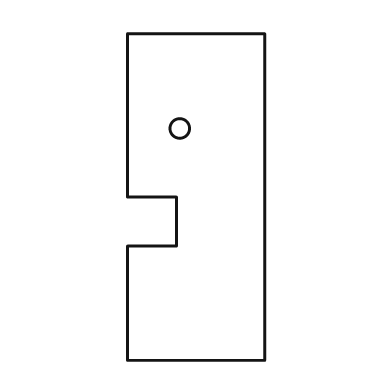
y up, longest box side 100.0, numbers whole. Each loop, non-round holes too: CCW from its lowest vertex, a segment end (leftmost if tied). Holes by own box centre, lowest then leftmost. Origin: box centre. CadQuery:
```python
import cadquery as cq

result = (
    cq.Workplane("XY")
    .moveTo(-21.0, -50.0)
    .lineTo(21.0, -50.0)
    .lineTo(21.0, 50.0)
    .lineTo(-21.0, 50.0)
    .lineTo(-21.0, 0.0)
    .lineTo(-6.0, 0.0)
    .lineTo(-6.0, -15.0)
    .lineTo(-21.0, -15.0)
    .close()
    .moveTo(-5.0, 21.0)
    .circle(3.0)
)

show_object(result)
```